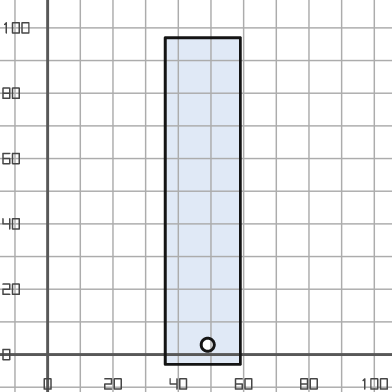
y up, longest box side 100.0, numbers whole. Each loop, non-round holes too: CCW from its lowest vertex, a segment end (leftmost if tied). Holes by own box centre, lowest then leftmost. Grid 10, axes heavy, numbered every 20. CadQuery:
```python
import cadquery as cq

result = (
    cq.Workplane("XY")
    .moveTo(36.0, -3.0)
    .lineTo(59.0, -3.0)
    .lineTo(59.0, 97.0)
    .lineTo(36.0, 97.0)
    .close()
    .moveTo(49.0, 3.0)
    .circle(2.0)
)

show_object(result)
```